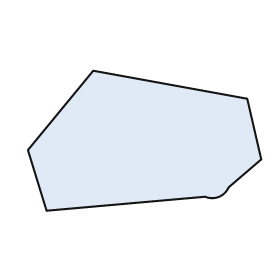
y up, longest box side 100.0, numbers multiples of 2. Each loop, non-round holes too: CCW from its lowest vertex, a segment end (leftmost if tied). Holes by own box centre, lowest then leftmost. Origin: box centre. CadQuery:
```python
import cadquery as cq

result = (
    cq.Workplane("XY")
    .moveTo(-42.0, -30.0)
    .lineTo(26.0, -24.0)
    .threePointArc((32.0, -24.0), (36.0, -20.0))
    .lineTo(50.0, -8.0)
    .lineTo(44.0, 18.0)
    .lineTo(-22.0, 30.0)
    .lineTo(-50.0, -4.0)
    .close()
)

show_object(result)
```